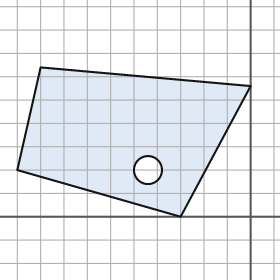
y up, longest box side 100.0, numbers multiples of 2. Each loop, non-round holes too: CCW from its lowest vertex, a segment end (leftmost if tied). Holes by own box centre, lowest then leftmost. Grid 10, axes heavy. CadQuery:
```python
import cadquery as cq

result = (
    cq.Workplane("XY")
    .moveTo(-30.0, 0.0)
    .lineTo(0.0, 56.0)
    .lineTo(-90.0, 64.0)
    .lineTo(-100.0, 20.0)
    .close()
    .moveTo(-44.0, 20.0)
    .circle(6.0)
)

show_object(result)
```